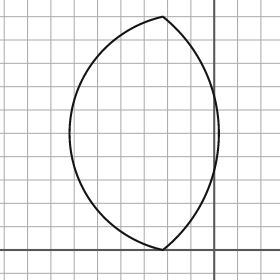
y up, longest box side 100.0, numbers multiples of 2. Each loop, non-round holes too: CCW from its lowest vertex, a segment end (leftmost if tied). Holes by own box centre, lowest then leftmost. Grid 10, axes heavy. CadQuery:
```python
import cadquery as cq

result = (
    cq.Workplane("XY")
    .moveTo(-22.0, 0.0)
    .threePointArc((2.0, 50.0), (-22.0, 100.0))
    .threePointArc((-62.0, 50.0), (-22.0, 0.0))
    .close()
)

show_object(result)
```